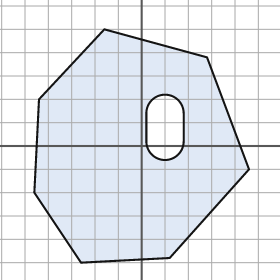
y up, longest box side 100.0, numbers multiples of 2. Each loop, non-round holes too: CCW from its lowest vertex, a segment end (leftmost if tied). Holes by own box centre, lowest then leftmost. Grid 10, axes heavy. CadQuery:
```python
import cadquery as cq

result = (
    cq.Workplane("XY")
    .moveTo(-26.0, -50.0)
    .lineTo(12.0, -48.0)
    .lineTo(46.0, -10.0)
    .lineTo(28.0, 38.0)
    .lineTo(-16.0, 50.0)
    .lineTo(-44.0, 20.0)
    .lineTo(-46.0, -20.0)
    .close()
    .moveTo(2.0, 2.0)
    .threePointArc((10.0, -6.0), (18.0, 2.0))
    .lineTo(18.0, 14.0)
    .threePointArc((10.0, 22.0), (2.0, 14.0))
    .close()
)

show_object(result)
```